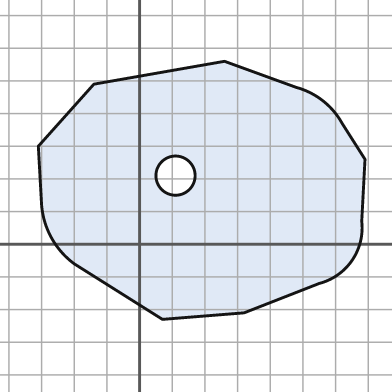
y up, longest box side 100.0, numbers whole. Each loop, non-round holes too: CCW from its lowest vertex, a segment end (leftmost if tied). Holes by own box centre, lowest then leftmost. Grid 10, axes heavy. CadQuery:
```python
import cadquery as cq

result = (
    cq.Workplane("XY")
    .moveTo(7.0, -23.0)
    .lineTo(32.0, -21.0)
    .lineTo(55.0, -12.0)
    .threePointArc((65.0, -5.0), (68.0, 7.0))
    .lineTo(69.0, 26.0)
    .lineTo(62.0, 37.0)
    .threePointArc((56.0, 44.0), (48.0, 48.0))
    .lineTo(26.0, 56.0)
    .lineTo(-14.0, 49.0)
    .lineTo(-31.0, 30.0)
    .lineTo(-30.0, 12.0)
    .threePointArc((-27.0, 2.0), (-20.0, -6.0))
    .close()
    .moveTo(11.0, 21.0)
    .circle(6.0)
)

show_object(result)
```